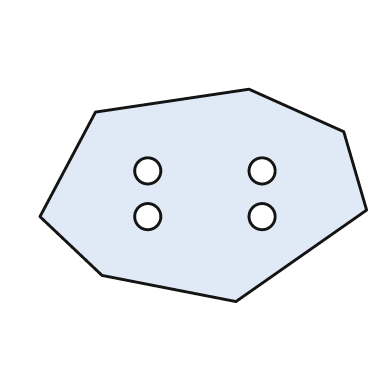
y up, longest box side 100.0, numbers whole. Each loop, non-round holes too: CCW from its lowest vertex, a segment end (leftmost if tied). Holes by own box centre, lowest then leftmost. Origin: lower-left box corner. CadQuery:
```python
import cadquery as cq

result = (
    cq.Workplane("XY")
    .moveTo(60.0, 0.0)
    .lineTo(100.0, 28.0)
    .lineTo(93.0, 52.0)
    .lineTo(64.0, 65.0)
    .lineTo(17.0, 58.0)
    .lineTo(0.0, 26.0)
    .lineTo(19.0, 8.0)
    .close()
    .moveTo(33.0, 26.0)
    .circle(4.0)
    .moveTo(68.0, 26.0)
    .circle(4.0)
    .moveTo(33.0, 40.0)
    .circle(4.0)
    .moveTo(68.0, 40.0)
    .circle(4.0)
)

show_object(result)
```